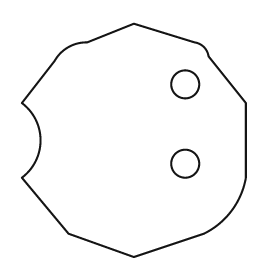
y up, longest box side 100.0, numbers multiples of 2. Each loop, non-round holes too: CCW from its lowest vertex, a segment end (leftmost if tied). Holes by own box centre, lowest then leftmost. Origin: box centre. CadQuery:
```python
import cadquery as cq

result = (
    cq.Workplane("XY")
    .moveTo(0.0, -50.0)
    .lineTo(30.0, -40.0)
    .threePointArc((42.0, -30.0), (48.0, -16.0))
    .lineTo(48.0, 16.0)
    .lineTo(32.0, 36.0)
    .threePointArc((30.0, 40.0), (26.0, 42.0))
    .lineTo(0.0, 50.0)
    .lineTo(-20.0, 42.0)
    .threePointArc((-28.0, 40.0), (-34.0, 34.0))
    .lineTo(-48.0, 16.0)
    .threePointArc((-40.0, 0.0), (-48.0, -16.0))
    .lineTo(-28.0, -40.0)
    .close()
    .moveTo(22.0, -10.0)
    .circle(6.0)
    .moveTo(22.0, 24.0)
    .circle(6.0)
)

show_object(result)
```